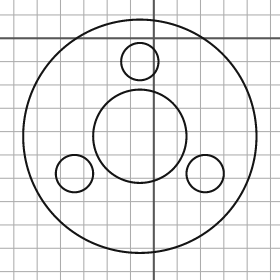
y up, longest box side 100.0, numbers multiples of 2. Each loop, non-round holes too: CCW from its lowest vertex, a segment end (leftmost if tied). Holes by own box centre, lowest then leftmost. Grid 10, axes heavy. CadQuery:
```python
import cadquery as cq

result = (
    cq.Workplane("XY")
    .moveTo(-6.0, -42.0)
    .circle(50.0)
    .moveTo(-34.0, -58.0)
    .circle(8.0)
    .moveTo(22.0, -58.0)
    .circle(8.0)
    .moveTo(-6.0, -42.0)
    .circle(20.0)
    .moveTo(-6.0, -10.0)
    .circle(8.0)
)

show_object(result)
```